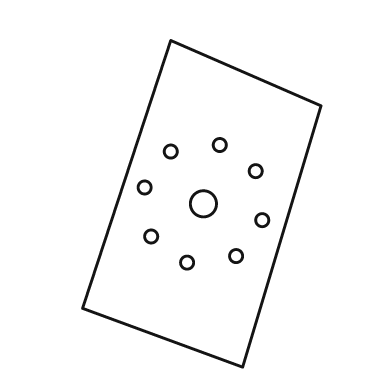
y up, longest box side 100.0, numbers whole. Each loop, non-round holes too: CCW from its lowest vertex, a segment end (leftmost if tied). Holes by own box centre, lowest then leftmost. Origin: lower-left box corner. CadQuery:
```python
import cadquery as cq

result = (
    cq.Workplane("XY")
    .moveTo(49.0, 0.0)
    .lineTo(73.0, 80.0)
    .lineTo(27.0, 100.0)
    .lineTo(0.0, 18.0)
    .close()
    .moveTo(32.0, 32.0)
    .circle(2.0)
    .moveTo(47.0, 34.0)
    .circle(2.0)
    .moveTo(21.0, 40.0)
    .circle(2.0)
    .moveTo(55.0, 45.0)
    .circle(2.0)
    .moveTo(37.0, 50.0)
    .circle(4.0)
    .moveTo(19.0, 55.0)
    .circle(2.0)
    .moveTo(53.0, 60.0)
    .circle(2.0)
    .moveTo(27.0, 66.0)
    .circle(2.0)
    .moveTo(42.0, 68.0)
    .circle(2.0)
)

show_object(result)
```